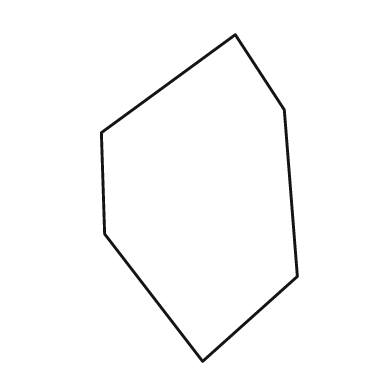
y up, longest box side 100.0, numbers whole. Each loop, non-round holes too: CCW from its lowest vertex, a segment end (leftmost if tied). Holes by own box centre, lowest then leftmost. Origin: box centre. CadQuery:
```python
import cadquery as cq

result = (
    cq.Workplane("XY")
    .moveTo(1.0, -50.0)
    .lineTo(30.0, -24.0)
    .lineTo(26.0, 27.0)
    .lineTo(11.0, 50.0)
    .lineTo(-30.0, 20.0)
    .lineTo(-29.0, -11.0)
    .close()
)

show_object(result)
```